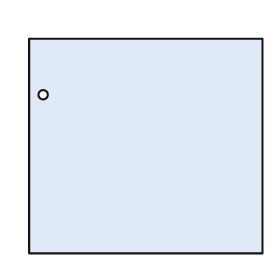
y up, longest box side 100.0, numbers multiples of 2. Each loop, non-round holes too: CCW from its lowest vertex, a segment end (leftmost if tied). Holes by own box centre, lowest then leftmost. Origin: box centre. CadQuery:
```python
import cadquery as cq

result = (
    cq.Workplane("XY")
    .moveTo(-50.0, -46.0)
    .lineTo(50.0, -46.0)
    .lineTo(50.0, 46.0)
    .lineTo(-50.0, 46.0)
    .close()
    .moveTo(-44.0, 22.0)
    .circle(2.0)
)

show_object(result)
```